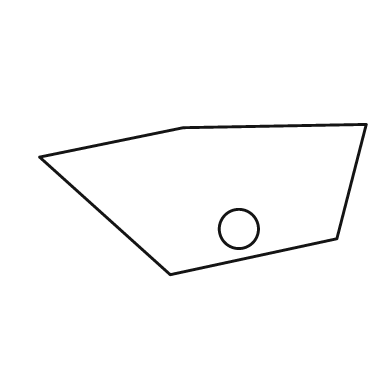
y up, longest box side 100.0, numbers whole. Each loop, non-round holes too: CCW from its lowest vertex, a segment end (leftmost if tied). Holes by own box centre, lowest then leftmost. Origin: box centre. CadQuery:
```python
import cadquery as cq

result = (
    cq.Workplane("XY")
    .moveTo(-10.0, -23.0)
    .lineTo(41.0, -12.0)
    .lineTo(50.0, 23.0)
    .lineTo(-6.0, 22.0)
    .lineTo(-50.0, 13.0)
    .close()
    .moveTo(11.0, -9.0)
    .circle(6.0)
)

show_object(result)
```